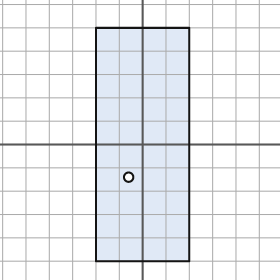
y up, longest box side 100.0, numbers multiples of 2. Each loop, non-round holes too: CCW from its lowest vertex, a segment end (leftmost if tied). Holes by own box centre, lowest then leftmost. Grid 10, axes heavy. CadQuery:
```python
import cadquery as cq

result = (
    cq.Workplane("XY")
    .moveTo(-20.0, -50.0)
    .lineTo(20.0, -50.0)
    .lineTo(20.0, 50.0)
    .lineTo(-20.0, 50.0)
    .close()
    .moveTo(-6.0, -14.0)
    .circle(2.0)
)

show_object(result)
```